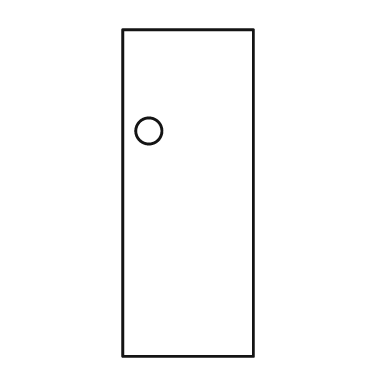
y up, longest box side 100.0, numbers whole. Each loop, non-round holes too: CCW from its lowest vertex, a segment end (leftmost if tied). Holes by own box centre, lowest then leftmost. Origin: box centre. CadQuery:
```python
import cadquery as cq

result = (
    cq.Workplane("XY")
    .moveTo(-20.0, -50.0)
    .lineTo(20.0, -50.0)
    .lineTo(20.0, 50.0)
    .lineTo(-20.0, 50.0)
    .close()
    .moveTo(-12.0, 19.0)
    .circle(4.0)
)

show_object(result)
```